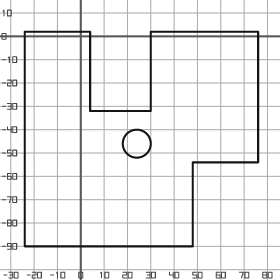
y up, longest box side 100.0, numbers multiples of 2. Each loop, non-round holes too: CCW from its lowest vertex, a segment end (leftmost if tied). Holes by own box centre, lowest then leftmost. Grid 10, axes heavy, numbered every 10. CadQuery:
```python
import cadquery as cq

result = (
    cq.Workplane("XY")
    .moveTo(-24.0, -90.0)
    .lineTo(48.0, -90.0)
    .lineTo(48.0, -54.0)
    .lineTo(76.0, -54.0)
    .lineTo(76.0, 2.0)
    .lineTo(30.0, 2.0)
    .lineTo(30.0, -32.0)
    .lineTo(4.0, -32.0)
    .lineTo(4.0, 2.0)
    .lineTo(-24.0, 2.0)
    .close()
    .moveTo(24.0, -46.0)
    .circle(6.0)
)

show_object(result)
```